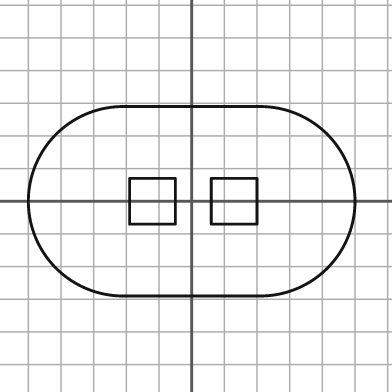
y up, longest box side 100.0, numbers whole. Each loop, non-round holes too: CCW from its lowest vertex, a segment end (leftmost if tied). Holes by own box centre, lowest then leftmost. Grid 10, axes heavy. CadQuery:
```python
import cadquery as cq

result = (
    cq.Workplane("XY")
    .moveTo(-21.0, -29.0)
    .lineTo(21.0, -29.0)
    .threePointArc((50.0, 0.0), (21.0, 29.0))
    .lineTo(-21.0, 29.0)
    .threePointArc((-50.0, 0.0), (-21.0, -29.0))
    .close()
    .moveTo(-19.0, -7.0)
    .lineTo(-5.0, -7.0)
    .lineTo(-5.0, 7.0)
    .lineTo(-19.0, 7.0)
    .close()
    .moveTo(6.0, -7.0)
    .lineTo(20.0, -7.0)
    .lineTo(20.0, 7.0)
    .lineTo(6.0, 7.0)
    .close()
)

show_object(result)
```